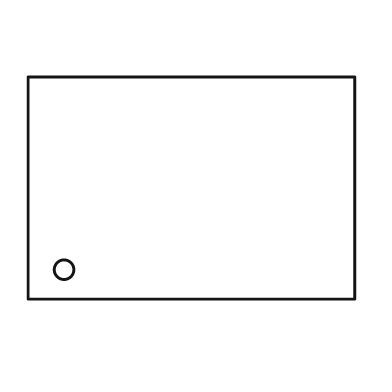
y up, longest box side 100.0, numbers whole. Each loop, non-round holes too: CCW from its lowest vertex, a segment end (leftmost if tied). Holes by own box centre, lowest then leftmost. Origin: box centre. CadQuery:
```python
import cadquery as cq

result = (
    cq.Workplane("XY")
    .moveTo(-50.0, -34.0)
    .lineTo(50.0, -34.0)
    .lineTo(50.0, 34.0)
    .lineTo(-50.0, 34.0)
    .close()
    .moveTo(-39.0, -25.0)
    .circle(3.0)
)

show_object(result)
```